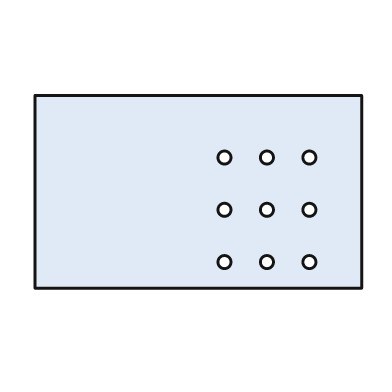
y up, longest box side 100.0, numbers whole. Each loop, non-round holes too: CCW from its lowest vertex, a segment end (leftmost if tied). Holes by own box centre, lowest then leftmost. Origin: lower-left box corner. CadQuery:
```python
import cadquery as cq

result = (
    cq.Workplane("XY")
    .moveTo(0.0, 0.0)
    .lineTo(100.0, 0.0)
    .lineTo(100.0, 59.0)
    .lineTo(0.0, 59.0)
    .close()
    .moveTo(58.0, 8.0)
    .circle(2.0)
    .moveTo(71.0, 8.0)
    .circle(2.0)
    .moveTo(84.0, 8.0)
    .circle(2.0)
    .moveTo(58.0, 24.0)
    .circle(2.0)
    .moveTo(71.0, 24.0)
    .circle(2.0)
    .moveTo(84.0, 24.0)
    .circle(2.0)
    .moveTo(58.0, 40.0)
    .circle(2.0)
    .moveTo(71.0, 40.0)
    .circle(2.0)
    .moveTo(84.0, 40.0)
    .circle(2.0)
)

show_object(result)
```